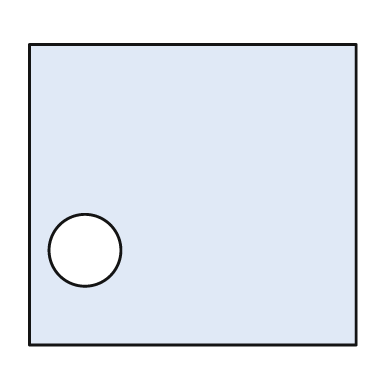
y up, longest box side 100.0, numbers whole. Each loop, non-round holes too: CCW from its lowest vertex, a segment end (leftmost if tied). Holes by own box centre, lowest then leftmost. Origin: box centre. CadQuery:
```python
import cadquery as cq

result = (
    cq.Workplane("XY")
    .moveTo(-50.0, -46.0)
    .lineTo(50.0, -46.0)
    .lineTo(50.0, 46.0)
    .lineTo(-50.0, 46.0)
    .close()
    .moveTo(-33.0, -17.0)
    .circle(11.0)
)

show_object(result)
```